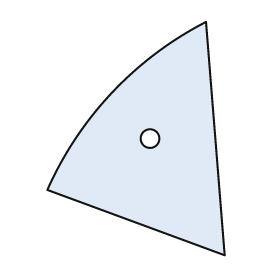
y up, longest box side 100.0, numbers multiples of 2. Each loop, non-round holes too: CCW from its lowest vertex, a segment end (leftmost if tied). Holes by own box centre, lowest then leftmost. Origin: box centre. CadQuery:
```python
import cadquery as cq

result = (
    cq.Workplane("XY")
    .moveTo(38.0, -50.0)
    .lineTo(30.0, 50.0)
    .threePointArc((-10.0, 20.0), (-38.0, -22.0))
    .close()
    .moveTo(6.0, 0.0)
    .circle(4.0)
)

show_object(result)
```